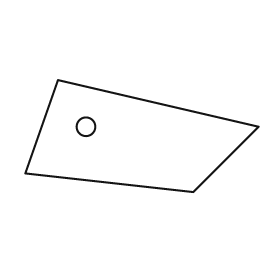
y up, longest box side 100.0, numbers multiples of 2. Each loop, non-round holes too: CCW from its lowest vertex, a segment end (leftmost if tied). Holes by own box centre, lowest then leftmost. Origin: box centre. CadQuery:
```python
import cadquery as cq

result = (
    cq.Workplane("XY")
    .moveTo(22.0, -24.0)
    .lineTo(50.0, 4.0)
    .lineTo(-36.0, 24.0)
    .lineTo(-50.0, -16.0)
    .close()
    .moveTo(-24.0, 4.0)
    .circle(4.0)
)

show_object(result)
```